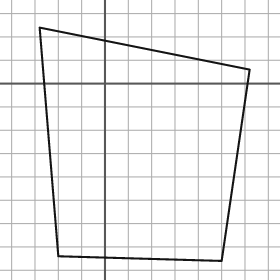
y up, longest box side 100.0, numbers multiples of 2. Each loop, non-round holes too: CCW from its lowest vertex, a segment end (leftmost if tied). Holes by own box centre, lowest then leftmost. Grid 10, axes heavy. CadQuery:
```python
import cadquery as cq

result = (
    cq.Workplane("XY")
    .moveTo(50.0, -76.0)
    .lineTo(62.0, 6.0)
    .lineTo(-28.0, 24.0)
    .lineTo(-20.0, -74.0)
    .close()
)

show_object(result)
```